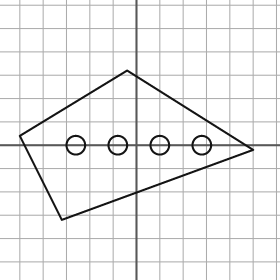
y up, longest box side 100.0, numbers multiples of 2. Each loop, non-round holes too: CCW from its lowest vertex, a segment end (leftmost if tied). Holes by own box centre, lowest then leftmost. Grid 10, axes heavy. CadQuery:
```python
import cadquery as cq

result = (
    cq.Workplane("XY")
    .moveTo(-32.0, -32.0)
    .lineTo(50.0, -2.0)
    .lineTo(-4.0, 32.0)
    .lineTo(-50.0, 4.0)
    .close()
    .moveTo(-26.0, 0.0)
    .circle(4.0)
    .moveTo(-8.0, 0.0)
    .circle(4.0)
    .moveTo(10.0, 0.0)
    .circle(4.0)
    .moveTo(28.0, 0.0)
    .circle(4.0)
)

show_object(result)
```